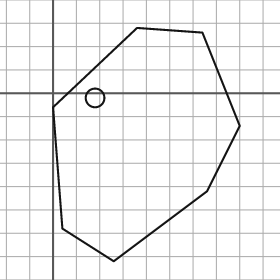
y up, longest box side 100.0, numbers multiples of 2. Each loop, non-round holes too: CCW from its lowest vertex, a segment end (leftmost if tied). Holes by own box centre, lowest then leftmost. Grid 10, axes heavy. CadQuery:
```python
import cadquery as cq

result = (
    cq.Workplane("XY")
    .moveTo(26.0, -72.0)
    .lineTo(66.0, -42.0)
    .lineTo(80.0, -14.0)
    .lineTo(64.0, 26.0)
    .lineTo(36.0, 28.0)
    .lineTo(0.0, -6.0)
    .lineTo(4.0, -58.0)
    .close()
    .moveTo(18.0, -2.0)
    .circle(4.0)
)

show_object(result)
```